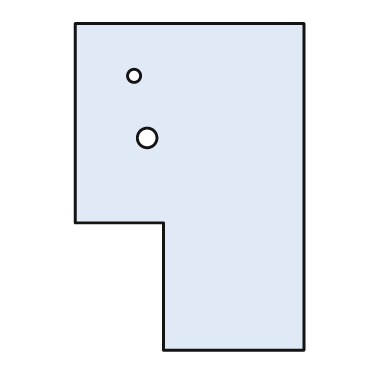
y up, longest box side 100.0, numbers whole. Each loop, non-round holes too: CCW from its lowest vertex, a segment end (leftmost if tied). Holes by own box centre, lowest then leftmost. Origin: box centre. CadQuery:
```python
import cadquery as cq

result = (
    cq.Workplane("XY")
    .moveTo(-8.0, -50.0)
    .lineTo(35.0, -50.0)
    .lineTo(35.0, 50.0)
    .lineTo(-35.0, 50.0)
    .lineTo(-35.0, -11.0)
    .lineTo(-8.0, -11.0)
    .close()
    .moveTo(-13.0, 15.0)
    .circle(3.0)
    .moveTo(-17.0, 34.0)
    .circle(2.0)
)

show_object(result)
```